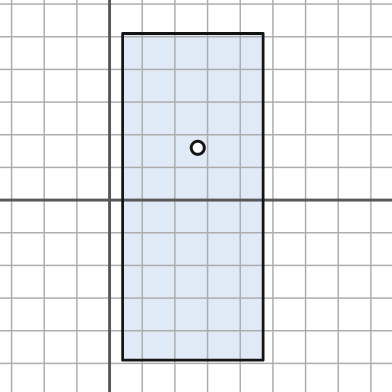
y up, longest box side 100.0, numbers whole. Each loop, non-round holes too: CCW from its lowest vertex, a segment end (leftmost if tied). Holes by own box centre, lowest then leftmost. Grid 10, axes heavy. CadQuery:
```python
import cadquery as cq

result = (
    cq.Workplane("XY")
    .moveTo(4.0, -49.0)
    .lineTo(47.0, -49.0)
    .lineTo(47.0, 51.0)
    .lineTo(4.0, 51.0)
    .close()
    .moveTo(27.0, 16.0)
    .circle(2.0)
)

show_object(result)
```